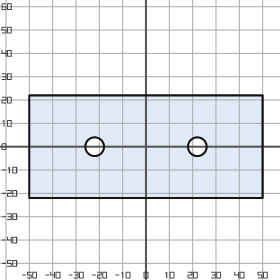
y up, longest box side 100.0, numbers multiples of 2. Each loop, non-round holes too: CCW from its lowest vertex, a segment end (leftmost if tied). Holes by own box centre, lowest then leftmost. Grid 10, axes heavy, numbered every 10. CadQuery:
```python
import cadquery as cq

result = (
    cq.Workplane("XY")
    .moveTo(-50.0, -22.0)
    .lineTo(50.0, -22.0)
    .lineTo(50.0, 22.0)
    .lineTo(-50.0, 22.0)
    .close()
    .moveTo(-22.0, 0.0)
    .circle(4.0)
    .moveTo(22.0, 0.0)
    .circle(4.0)
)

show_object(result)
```